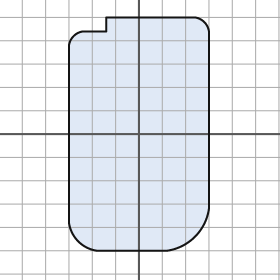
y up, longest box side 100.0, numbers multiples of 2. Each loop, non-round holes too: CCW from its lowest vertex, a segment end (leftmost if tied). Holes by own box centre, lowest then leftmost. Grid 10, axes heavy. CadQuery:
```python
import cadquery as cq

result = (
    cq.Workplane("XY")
    .moveTo(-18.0, -50.0)
    .lineTo(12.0, -50.0)
    .threePointArc((24.0, -44.0), (30.0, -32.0))
    .lineTo(30.0, 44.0)
    .threePointArc((28.0, 48.0), (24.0, 50.0))
    .lineTo(-14.0, 50.0)
    .lineTo(-14.0, 44.0)
    .lineTo(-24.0, 44.0)
    .threePointArc((-28.0, 42.0), (-30.0, 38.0))
    .lineTo(-30.0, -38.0)
    .threePointArc((-26.0, -46.0), (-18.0, -50.0))
    .close()
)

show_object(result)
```